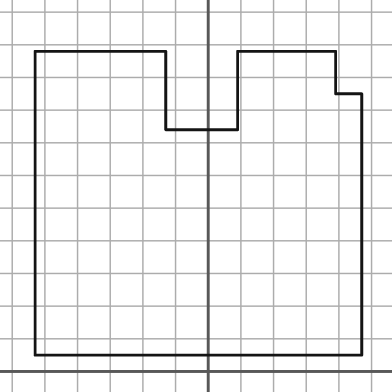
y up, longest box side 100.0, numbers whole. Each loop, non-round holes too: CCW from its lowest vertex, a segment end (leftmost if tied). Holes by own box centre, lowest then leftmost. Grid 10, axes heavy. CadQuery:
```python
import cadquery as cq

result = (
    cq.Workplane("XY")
    .moveTo(-53.0, 5.0)
    .lineTo(47.0, 5.0)
    .lineTo(47.0, 85.0)
    .lineTo(39.0, 85.0)
    .lineTo(39.0, 98.0)
    .lineTo(9.0, 98.0)
    .lineTo(9.0, 74.0)
    .lineTo(-13.0, 74.0)
    .lineTo(-13.0, 98.0)
    .lineTo(-53.0, 98.0)
    .close()
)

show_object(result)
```